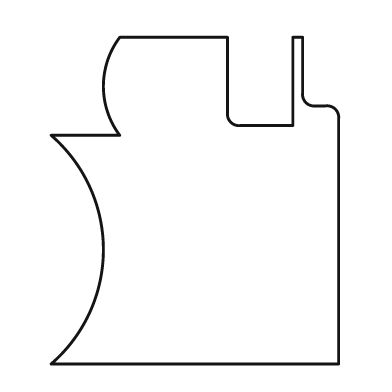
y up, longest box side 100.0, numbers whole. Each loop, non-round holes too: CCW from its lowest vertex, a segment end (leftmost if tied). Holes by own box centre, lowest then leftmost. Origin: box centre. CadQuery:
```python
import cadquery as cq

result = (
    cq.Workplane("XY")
    .moveTo(-44.0, -50.0)
    .lineTo(44.0, -50.0)
    .lineTo(44.0, 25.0)
    .threePointArc((43.0, 28.0), (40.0, 29.0))
    .lineTo(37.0, 29.0)
    .threePointArc((34.0, 30.0), (33.0, 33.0))
    .lineTo(33.0, 50.0)
    .lineTo(30.0, 50.0)
    .lineTo(30.0, 23.0)
    .lineTo(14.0, 23.0)
    .threePointArc((11.0, 24.0), (10.0, 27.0))
    .lineTo(10.0, 50.0)
    .lineTo(-23.0, 50.0)
    .threePointArc((-28.0, 35.0), (-23.0, 20.0))
    .lineTo(-44.0, 20.0)
    .threePointArc((-28.0, -15.0), (-44.0, -50.0))
    .close()
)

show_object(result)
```